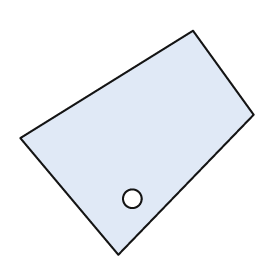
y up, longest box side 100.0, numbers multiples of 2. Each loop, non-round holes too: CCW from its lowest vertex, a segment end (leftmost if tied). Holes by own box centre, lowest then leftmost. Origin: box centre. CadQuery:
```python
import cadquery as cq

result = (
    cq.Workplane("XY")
    .moveTo(-8.0, -48.0)
    .lineTo(50.0, 12.0)
    .lineTo(24.0, 48.0)
    .lineTo(-50.0, 2.0)
    .close()
    .moveTo(-2.0, -24.0)
    .circle(4.0)
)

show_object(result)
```